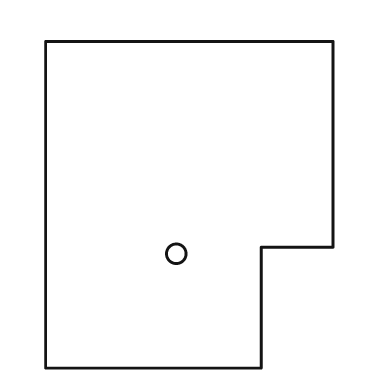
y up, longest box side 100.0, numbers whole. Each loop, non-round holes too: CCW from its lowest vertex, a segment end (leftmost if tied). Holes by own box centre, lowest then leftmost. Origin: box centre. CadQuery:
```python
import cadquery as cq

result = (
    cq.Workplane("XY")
    .moveTo(-44.0, -50.0)
    .lineTo(22.0, -50.0)
    .lineTo(22.0, -13.0)
    .lineTo(44.0, -13.0)
    .lineTo(44.0, 50.0)
    .lineTo(-44.0, 50.0)
    .close()
    .moveTo(-4.0, -15.0)
    .circle(3.0)
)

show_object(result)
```